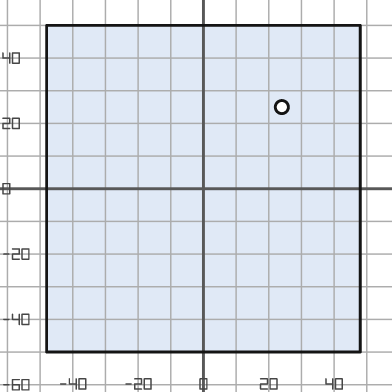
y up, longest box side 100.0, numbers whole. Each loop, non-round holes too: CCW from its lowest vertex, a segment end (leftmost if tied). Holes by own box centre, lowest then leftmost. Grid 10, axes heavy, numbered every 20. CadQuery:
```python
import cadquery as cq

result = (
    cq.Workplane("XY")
    .moveTo(-48.0, -50.0)
    .lineTo(48.0, -50.0)
    .lineTo(48.0, 50.0)
    .lineTo(-48.0, 50.0)
    .close()
    .moveTo(24.0, 25.0)
    .circle(2.0)
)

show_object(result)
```